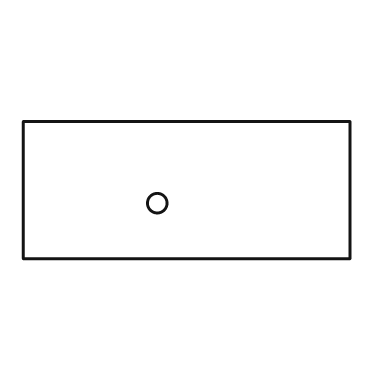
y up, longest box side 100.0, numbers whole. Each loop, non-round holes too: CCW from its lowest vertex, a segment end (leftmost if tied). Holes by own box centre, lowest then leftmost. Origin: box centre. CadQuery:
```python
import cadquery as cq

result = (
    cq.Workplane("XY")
    .moveTo(-50.0, -21.0)
    .lineTo(50.0, -21.0)
    .lineTo(50.0, 21.0)
    .lineTo(-50.0, 21.0)
    .close()
    .moveTo(-9.0, -4.0)
    .circle(3.0)
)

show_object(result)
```